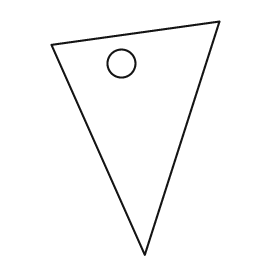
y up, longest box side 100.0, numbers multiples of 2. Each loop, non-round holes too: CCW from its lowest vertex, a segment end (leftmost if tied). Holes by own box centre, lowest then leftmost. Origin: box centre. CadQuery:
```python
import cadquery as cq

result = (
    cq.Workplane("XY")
    .moveTo(4.0, -50.0)
    .lineTo(36.0, 50.0)
    .lineTo(-36.0, 40.0)
    .close()
    .moveTo(-6.0, 32.0)
    .circle(6.0)
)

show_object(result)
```